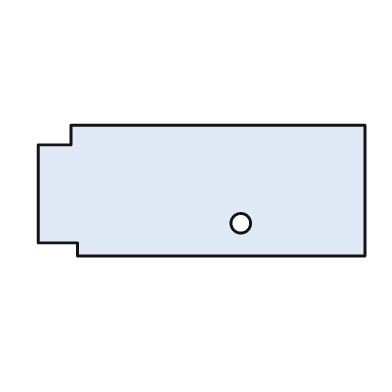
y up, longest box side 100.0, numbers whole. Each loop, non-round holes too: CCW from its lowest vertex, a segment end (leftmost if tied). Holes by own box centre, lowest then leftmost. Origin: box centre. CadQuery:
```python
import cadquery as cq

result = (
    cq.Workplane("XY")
    .moveTo(-38.0, -20.0)
    .lineTo(50.0, -20.0)
    .lineTo(50.0, 20.0)
    .lineTo(-40.0, 20.0)
    .lineTo(-40.0, 14.0)
    .lineTo(-50.0, 14.0)
    .lineTo(-50.0, -16.0)
    .lineTo(-38.0, -16.0)
    .close()
    .moveTo(12.0, -10.0)
    .circle(3.0)
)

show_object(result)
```